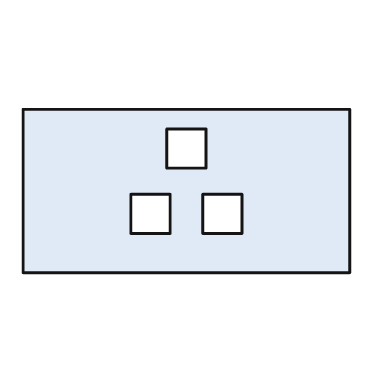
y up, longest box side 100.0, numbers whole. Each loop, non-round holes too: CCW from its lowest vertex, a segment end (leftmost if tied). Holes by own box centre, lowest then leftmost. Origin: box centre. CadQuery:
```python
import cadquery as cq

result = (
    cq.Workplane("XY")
    .moveTo(-50.0, -25.0)
    .lineTo(50.0, -25.0)
    .lineTo(50.0, 25.0)
    .lineTo(-50.0, 25.0)
    .close()
    .moveTo(-17.0, -13.0)
    .lineTo(-5.0, -13.0)
    .lineTo(-5.0, -1.0)
    .lineTo(-17.0, -1.0)
    .close()
    .moveTo(5.0, -13.0)
    .lineTo(17.0, -13.0)
    .lineTo(17.0, -1.0)
    .lineTo(5.0, -1.0)
    .close()
    .moveTo(-6.0, 7.0)
    .lineTo(6.0, 7.0)
    .lineTo(6.0, 19.0)
    .lineTo(-6.0, 19.0)
    .close()
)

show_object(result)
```